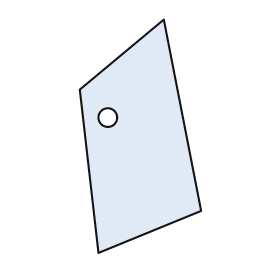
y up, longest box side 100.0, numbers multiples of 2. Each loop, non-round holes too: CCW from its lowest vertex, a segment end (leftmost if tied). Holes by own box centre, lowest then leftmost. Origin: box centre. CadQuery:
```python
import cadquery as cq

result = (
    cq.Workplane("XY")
    .moveTo(-18.0, -50.0)
    .lineTo(26.0, -32.0)
    .lineTo(10.0, 50.0)
    .lineTo(-26.0, 20.0)
    .close()
    .moveTo(-14.0, 8.0)
    .circle(4.0)
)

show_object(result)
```